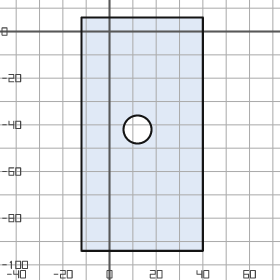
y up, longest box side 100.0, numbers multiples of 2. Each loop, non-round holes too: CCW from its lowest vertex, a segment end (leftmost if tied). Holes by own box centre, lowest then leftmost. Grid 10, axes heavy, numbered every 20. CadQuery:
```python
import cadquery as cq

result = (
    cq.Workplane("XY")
    .moveTo(-12.0, -94.0)
    .lineTo(40.0, -94.0)
    .lineTo(40.0, 6.0)
    .lineTo(-12.0, 6.0)
    .close()
    .moveTo(12.0, -42.0)
    .circle(6.0)
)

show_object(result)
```